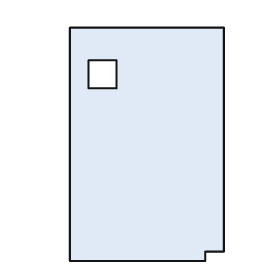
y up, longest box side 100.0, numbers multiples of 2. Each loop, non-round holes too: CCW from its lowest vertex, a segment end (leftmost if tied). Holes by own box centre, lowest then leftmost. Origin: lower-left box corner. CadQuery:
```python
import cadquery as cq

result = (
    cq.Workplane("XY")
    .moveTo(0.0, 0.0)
    .lineTo(58.0, 0.0)
    .lineTo(58.0, 4.0)
    .lineTo(66.0, 4.0)
    .lineTo(66.0, 100.0)
    .lineTo(0.0, 100.0)
    .close()
    .moveTo(8.0, 74.0)
    .lineTo(20.0, 74.0)
    .lineTo(20.0, 86.0)
    .lineTo(8.0, 86.0)
    .close()
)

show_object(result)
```